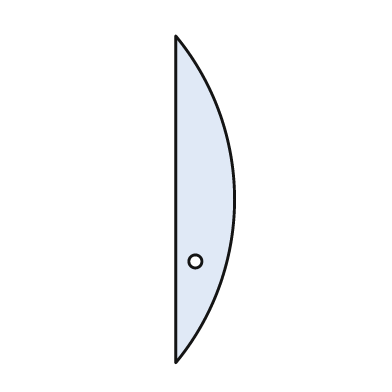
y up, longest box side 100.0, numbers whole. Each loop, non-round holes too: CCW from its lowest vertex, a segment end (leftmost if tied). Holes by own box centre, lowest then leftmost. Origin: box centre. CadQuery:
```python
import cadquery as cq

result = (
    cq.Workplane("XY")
    .moveTo(-9.0, -50.0)
    .threePointArc((9.0, 0.0), (-9.0, 50.0))
    .close()
    .moveTo(-3.0, -19.0)
    .circle(2.0)
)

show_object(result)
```